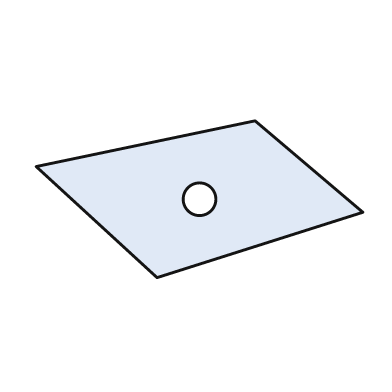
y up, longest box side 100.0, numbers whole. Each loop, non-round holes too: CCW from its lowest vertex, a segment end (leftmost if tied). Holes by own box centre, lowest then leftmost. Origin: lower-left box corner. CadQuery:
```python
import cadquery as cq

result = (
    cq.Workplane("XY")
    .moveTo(37.0, 0.0)
    .lineTo(100.0, 20.0)
    .lineTo(67.0, 48.0)
    .lineTo(0.0, 34.0)
    .close()
    .moveTo(50.0, 24.0)
    .circle(5.0)
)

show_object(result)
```